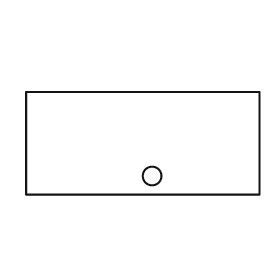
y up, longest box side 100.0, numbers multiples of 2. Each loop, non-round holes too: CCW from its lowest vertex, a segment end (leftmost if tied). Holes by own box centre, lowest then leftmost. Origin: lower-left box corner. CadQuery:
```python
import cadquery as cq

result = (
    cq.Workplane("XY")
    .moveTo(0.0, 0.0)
    .lineTo(100.0, 0.0)
    .lineTo(100.0, 44.0)
    .lineTo(0.0, 44.0)
    .close()
    .moveTo(54.0, 8.0)
    .circle(4.0)
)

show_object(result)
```